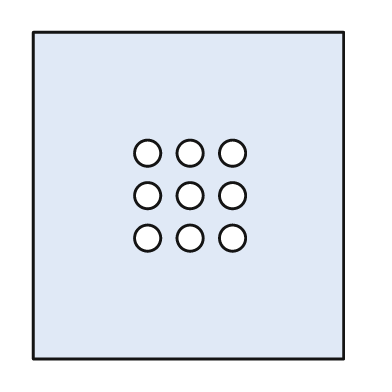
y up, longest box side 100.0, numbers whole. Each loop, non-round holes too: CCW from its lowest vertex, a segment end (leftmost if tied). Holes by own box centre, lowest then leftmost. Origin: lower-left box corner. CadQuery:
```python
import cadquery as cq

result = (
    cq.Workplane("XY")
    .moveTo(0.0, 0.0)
    .lineTo(95.0, 0.0)
    .lineTo(95.0, 100.0)
    .lineTo(0.0, 100.0)
    .close()
    .moveTo(35.0, 37.0)
    .circle(4.0)
    .moveTo(48.0, 37.0)
    .circle(4.0)
    .moveTo(61.0, 37.0)
    .circle(4.0)
    .moveTo(35.0, 50.0)
    .circle(4.0)
    .moveTo(48.0, 50.0)
    .circle(4.0)
    .moveTo(61.0, 50.0)
    .circle(4.0)
    .moveTo(35.0, 63.0)
    .circle(4.0)
    .moveTo(48.0, 63.0)
    .circle(4.0)
    .moveTo(61.0, 63.0)
    .circle(4.0)
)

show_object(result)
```